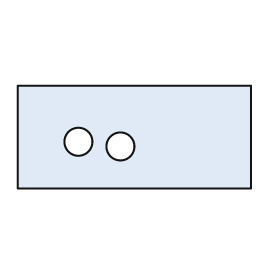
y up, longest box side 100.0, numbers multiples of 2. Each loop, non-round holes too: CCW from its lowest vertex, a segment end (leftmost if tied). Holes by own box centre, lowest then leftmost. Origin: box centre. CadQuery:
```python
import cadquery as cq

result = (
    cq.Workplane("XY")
    .moveTo(-50.0, -22.0)
    .lineTo(50.0, -22.0)
    .lineTo(50.0, 22.0)
    .lineTo(-50.0, 22.0)
    .close()
    .moveTo(-6.0, -4.0)
    .circle(6.0)
    .moveTo(-24.0, -2.0)
    .circle(6.0)
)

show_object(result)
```